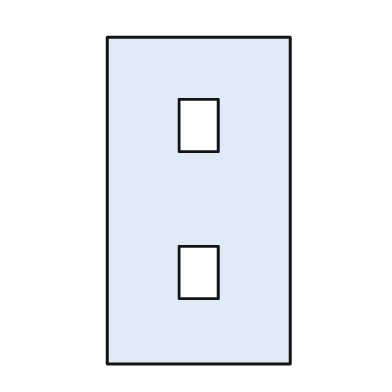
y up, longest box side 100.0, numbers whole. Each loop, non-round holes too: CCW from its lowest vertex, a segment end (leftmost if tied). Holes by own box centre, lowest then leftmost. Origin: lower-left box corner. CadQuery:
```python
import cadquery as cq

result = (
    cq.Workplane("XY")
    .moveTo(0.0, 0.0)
    .lineTo(56.0, 0.0)
    .lineTo(56.0, 100.0)
    .lineTo(0.0, 100.0)
    .close()
    .moveTo(22.0, 20.0)
    .lineTo(34.0, 20.0)
    .lineTo(34.0, 36.0)
    .lineTo(22.0, 36.0)
    .close()
    .moveTo(22.0, 65.0)
    .lineTo(34.0, 65.0)
    .lineTo(34.0, 81.0)
    .lineTo(22.0, 81.0)
    .close()
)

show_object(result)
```